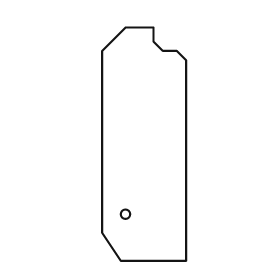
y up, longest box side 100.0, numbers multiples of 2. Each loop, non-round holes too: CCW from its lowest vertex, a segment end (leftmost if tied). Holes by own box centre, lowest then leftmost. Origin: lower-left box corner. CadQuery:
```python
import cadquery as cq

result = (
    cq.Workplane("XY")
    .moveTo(8.0, 0.0)
    .lineTo(36.0, 0.0)
    .lineTo(36.0, 86.0)
    .lineTo(32.0, 90.0)
    .lineTo(26.0, 90.0)
    .lineTo(22.0, 94.0)
    .lineTo(22.0, 100.0)
    .lineTo(10.0, 100.0)
    .lineTo(0.0, 90.0)
    .lineTo(0.0, 12.0)
    .close()
    .moveTo(10.0, 20.0)
    .circle(2.0)
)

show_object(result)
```